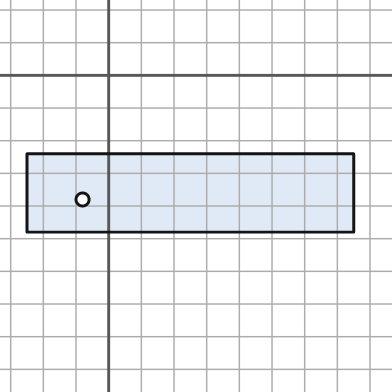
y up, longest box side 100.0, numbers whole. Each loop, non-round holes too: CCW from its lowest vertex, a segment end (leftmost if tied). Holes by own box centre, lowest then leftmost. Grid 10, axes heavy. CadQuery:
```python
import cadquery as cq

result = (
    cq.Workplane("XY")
    .moveTo(-25.0, -48.0)
    .lineTo(75.0, -48.0)
    .lineTo(75.0, -24.0)
    .lineTo(-25.0, -24.0)
    .close()
    .moveTo(-8.0, -38.0)
    .circle(2.0)
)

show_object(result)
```